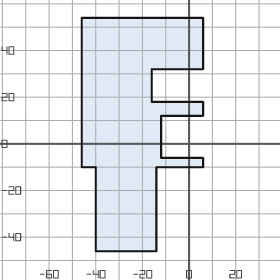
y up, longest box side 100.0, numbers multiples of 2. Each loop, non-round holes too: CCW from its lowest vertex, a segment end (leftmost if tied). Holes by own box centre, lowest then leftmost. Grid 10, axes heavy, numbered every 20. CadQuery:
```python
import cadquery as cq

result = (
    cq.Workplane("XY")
    .moveTo(-40.0, -46.0)
    .lineTo(-14.0, -46.0)
    .lineTo(-14.0, -10.0)
    .lineTo(6.0, -10.0)
    .lineTo(6.0, -6.0)
    .lineTo(-12.0, -6.0)
    .lineTo(-12.0, 12.0)
    .lineTo(6.0, 12.0)
    .lineTo(6.0, 18.0)
    .lineTo(-16.0, 18.0)
    .lineTo(-16.0, 32.0)
    .lineTo(6.0, 32.0)
    .lineTo(6.0, 54.0)
    .lineTo(-46.0, 54.0)
    .lineTo(-46.0, -10.0)
    .lineTo(-40.0, -10.0)
    .close()
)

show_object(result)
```